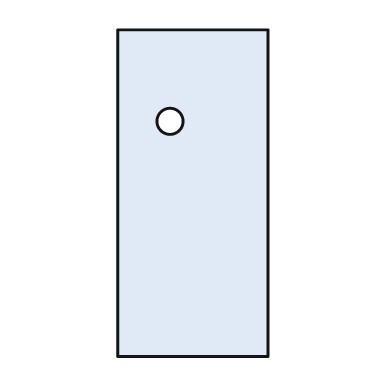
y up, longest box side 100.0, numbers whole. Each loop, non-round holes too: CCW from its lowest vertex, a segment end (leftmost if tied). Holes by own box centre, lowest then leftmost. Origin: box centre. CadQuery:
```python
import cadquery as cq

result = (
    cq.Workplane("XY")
    .moveTo(-23.0, -50.0)
    .lineTo(23.0, -50.0)
    .lineTo(23.0, 50.0)
    .lineTo(-23.0, 50.0)
    .close()
    .moveTo(-7.0, 22.0)
    .circle(4.0)
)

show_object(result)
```